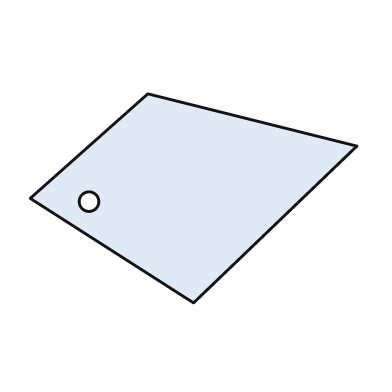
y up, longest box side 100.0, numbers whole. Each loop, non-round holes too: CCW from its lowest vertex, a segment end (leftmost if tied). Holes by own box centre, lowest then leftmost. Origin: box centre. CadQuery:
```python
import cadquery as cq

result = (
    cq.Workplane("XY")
    .moveTo(0.0, -32.0)
    .lineTo(50.0, 16.0)
    .lineTo(-14.0, 32.0)
    .lineTo(-50.0, 0.0)
    .close()
    .moveTo(-32.0, -1.0)
    .circle(3.0)
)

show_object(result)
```